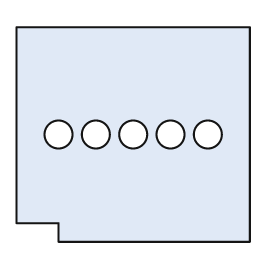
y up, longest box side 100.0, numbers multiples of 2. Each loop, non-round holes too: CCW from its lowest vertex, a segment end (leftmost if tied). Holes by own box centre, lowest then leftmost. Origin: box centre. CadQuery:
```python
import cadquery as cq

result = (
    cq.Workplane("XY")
    .moveTo(-32.0, -46.0)
    .lineTo(50.0, -46.0)
    .lineTo(50.0, 46.0)
    .lineTo(-50.0, 46.0)
    .lineTo(-50.0, -38.0)
    .lineTo(-32.0, -38.0)
    .close()
    .moveTo(-32.0, 0.0)
    .circle(6.0)
    .moveTo(-16.0, 0.0)
    .circle(6.0)
    .moveTo(0.0, 0.0)
    .circle(6.0)
    .moveTo(16.0, 0.0)
    .circle(6.0)
    .moveTo(32.0, 0.0)
    .circle(6.0)
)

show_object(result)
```